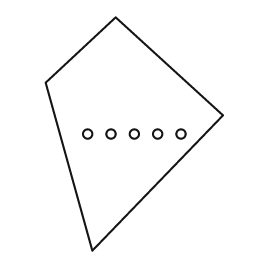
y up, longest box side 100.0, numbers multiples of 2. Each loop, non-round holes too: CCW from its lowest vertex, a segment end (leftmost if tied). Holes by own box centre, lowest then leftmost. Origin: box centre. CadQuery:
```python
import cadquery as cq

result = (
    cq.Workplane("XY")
    .moveTo(-18.0, -50.0)
    .lineTo(38.0, 8.0)
    .lineTo(-8.0, 50.0)
    .lineTo(-38.0, 22.0)
    .close()
    .moveTo(-20.0, 0.0)
    .circle(2.0)
    .moveTo(-10.0, 0.0)
    .circle(2.0)
    .moveTo(0.0, 0.0)
    .circle(2.0)
    .moveTo(10.0, 0.0)
    .circle(2.0)
    .moveTo(20.0, 0.0)
    .circle(2.0)
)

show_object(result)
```